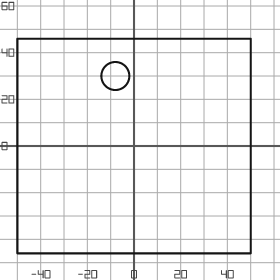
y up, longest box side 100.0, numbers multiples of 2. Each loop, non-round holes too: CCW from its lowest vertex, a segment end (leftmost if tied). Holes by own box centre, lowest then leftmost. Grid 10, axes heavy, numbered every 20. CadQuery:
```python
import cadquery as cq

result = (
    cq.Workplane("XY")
    .moveTo(-50.0, -46.0)
    .lineTo(50.0, -46.0)
    .lineTo(50.0, 46.0)
    .lineTo(-50.0, 46.0)
    .close()
    .moveTo(-8.0, 30.0)
    .circle(6.0)
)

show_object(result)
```